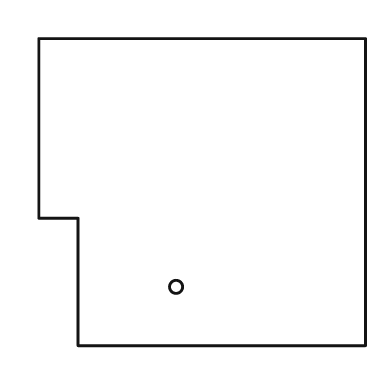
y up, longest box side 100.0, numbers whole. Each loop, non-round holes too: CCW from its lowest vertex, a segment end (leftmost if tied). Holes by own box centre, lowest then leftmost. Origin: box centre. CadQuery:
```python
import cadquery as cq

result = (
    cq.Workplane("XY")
    .moveTo(-38.0, -47.0)
    .lineTo(50.0, -47.0)
    .lineTo(50.0, 47.0)
    .lineTo(-50.0, 47.0)
    .lineTo(-50.0, -8.0)
    .lineTo(-38.0, -8.0)
    .close()
    .moveTo(-8.0, -29.0)
    .circle(2.0)
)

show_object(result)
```